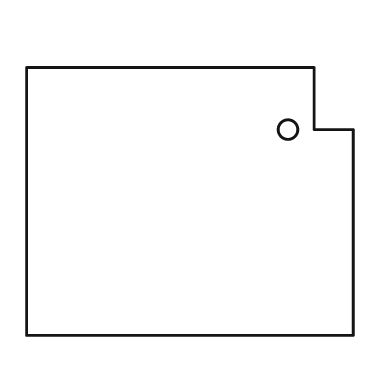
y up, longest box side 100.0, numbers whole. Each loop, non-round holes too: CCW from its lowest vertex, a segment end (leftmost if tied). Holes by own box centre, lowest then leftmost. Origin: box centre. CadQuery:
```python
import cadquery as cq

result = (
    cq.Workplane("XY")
    .moveTo(-50.0, -41.0)
    .lineTo(50.0, -41.0)
    .lineTo(50.0, 22.0)
    .lineTo(38.0, 22.0)
    .lineTo(38.0, 41.0)
    .lineTo(-50.0, 41.0)
    .close()
    .moveTo(30.0, 22.0)
    .circle(3.0)
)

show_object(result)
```